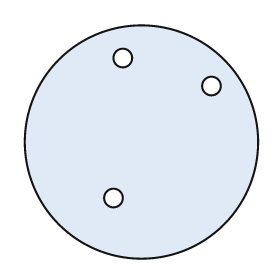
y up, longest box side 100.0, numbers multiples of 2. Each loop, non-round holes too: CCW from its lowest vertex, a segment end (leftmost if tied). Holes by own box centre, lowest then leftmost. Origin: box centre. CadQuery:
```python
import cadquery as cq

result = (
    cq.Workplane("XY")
    .moveTo(0.0, 0.0)
    .circle(50.0)
    .moveTo(-12.0, -24.0)
    .circle(4.0)
    .moveTo(30.0, 24.0)
    .circle(4.0)
    .moveTo(-8.0, 36.0)
    .circle(4.0)
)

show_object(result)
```